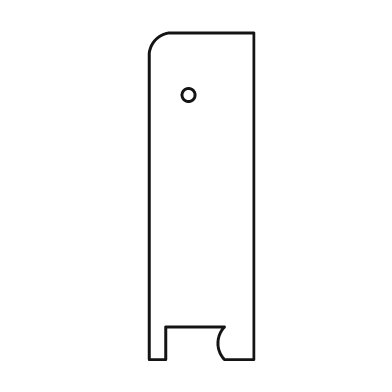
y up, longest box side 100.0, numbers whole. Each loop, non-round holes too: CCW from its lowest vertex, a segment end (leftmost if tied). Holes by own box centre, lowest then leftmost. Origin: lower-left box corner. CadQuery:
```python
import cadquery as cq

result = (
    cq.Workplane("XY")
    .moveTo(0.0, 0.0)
    .lineTo(5.0, 0.0)
    .lineTo(5.0, 10.0)
    .lineTo(23.0, 10.0)
    .threePointArc((21.0, 5.0), (23.0, 0.0))
    .lineTo(32.0, 0.0)
    .lineTo(32.0, 100.0)
    .lineTo(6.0, 100.0)
    .threePointArc((2.0, 98.0), (0.0, 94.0))
    .close()
    .moveTo(12.0, 81.0)
    .circle(2.0)
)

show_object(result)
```